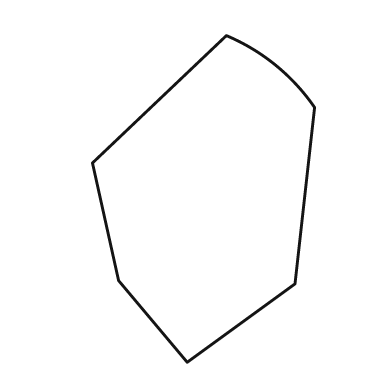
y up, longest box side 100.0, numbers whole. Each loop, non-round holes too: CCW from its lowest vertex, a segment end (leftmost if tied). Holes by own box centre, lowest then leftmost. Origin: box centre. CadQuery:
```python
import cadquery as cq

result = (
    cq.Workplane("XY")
    .moveTo(-5.0, -50.0)
    .lineTo(28.0, -26.0)
    .lineTo(34.0, 28.0)
    .threePointArc((22.0, 41.0), (7.0, 50.0))
    .lineTo(-34.0, 11.0)
    .lineTo(-26.0, -25.0)
    .close()
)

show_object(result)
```